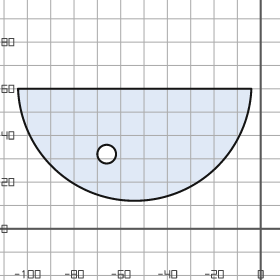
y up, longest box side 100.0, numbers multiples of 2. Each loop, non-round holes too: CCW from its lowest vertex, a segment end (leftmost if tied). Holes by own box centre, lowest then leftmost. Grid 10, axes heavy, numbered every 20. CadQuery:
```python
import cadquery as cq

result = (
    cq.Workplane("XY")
    .moveTo(-104.0, 60.0)
    .threePointArc((-54.0, 12.0), (-4.0, 60.0))
    .close()
    .moveTo(-66.0, 32.0)
    .circle(4.0)
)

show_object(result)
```